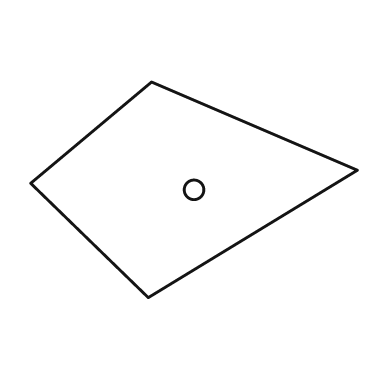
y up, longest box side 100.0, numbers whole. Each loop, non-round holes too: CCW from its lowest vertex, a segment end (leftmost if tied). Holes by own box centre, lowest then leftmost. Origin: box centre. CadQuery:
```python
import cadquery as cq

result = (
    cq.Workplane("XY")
    .moveTo(-14.0, -33.0)
    .lineTo(50.0, 6.0)
    .lineTo(-13.0, 33.0)
    .lineTo(-50.0, 2.0)
    .close()
    .moveTo(0.0, 0.0)
    .circle(3.0)
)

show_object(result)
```